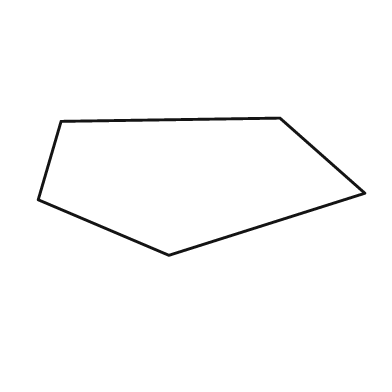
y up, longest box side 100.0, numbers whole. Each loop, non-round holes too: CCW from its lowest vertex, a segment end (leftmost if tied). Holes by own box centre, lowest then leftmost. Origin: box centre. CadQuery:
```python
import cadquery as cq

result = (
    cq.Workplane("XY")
    .moveTo(-10.0, -21.0)
    .lineTo(50.0, -2.0)
    .lineTo(24.0, 21.0)
    .lineTo(-43.0, 20.0)
    .lineTo(-50.0, -4.0)
    .close()
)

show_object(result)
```